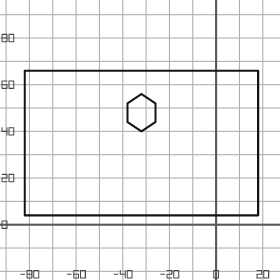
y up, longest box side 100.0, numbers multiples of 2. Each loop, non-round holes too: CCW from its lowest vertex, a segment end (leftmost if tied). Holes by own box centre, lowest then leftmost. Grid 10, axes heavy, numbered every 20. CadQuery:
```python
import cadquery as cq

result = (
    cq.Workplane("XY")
    .moveTo(-82.0, 4.0)
    .lineTo(18.0, 4.0)
    .lineTo(18.0, 66.0)
    .lineTo(-82.0, 66.0)
    .close()
    .moveTo(-32.0, 40.0)
    .lineTo(-26.0, 44.0)
    .lineTo(-26.0, 52.0)
    .lineTo(-32.0, 56.0)
    .lineTo(-38.0, 52.0)
    .lineTo(-38.0, 44.0)
    .close()
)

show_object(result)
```